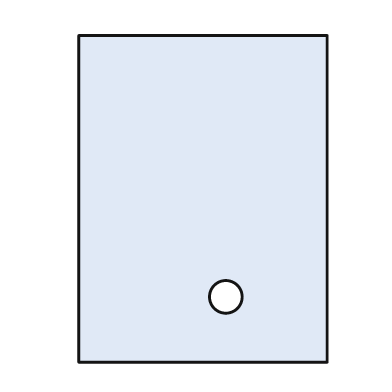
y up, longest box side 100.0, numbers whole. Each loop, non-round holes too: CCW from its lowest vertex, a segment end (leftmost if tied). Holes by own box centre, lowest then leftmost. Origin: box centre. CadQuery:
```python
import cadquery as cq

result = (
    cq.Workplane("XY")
    .moveTo(-38.0, -50.0)
    .lineTo(38.0, -50.0)
    .lineTo(38.0, 50.0)
    .lineTo(-38.0, 50.0)
    .close()
    .moveTo(7.0, -30.0)
    .circle(5.0)
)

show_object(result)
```